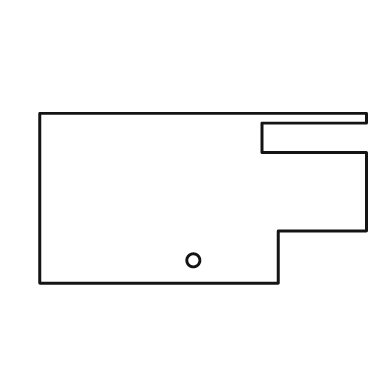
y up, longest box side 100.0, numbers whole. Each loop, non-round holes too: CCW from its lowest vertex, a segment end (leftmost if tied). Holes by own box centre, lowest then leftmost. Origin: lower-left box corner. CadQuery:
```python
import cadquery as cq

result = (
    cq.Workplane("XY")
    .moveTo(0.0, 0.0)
    .lineTo(73.0, 0.0)
    .lineTo(73.0, 16.0)
    .lineTo(100.0, 16.0)
    .lineTo(100.0, 40.0)
    .lineTo(68.0, 40.0)
    .lineTo(68.0, 49.0)
    .lineTo(100.0, 49.0)
    .lineTo(100.0, 52.0)
    .lineTo(0.0, 52.0)
    .close()
    .moveTo(47.0, 7.0)
    .circle(2.0)
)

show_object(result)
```